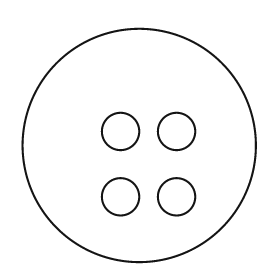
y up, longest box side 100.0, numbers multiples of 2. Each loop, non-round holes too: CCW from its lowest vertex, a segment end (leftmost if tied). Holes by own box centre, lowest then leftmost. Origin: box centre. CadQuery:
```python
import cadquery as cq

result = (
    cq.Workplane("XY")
    .moveTo(0.0, 0.0)
    .circle(50.0)
    .moveTo(-8.0, -22.0)
    .circle(8.0)
    .moveTo(16.0, -22.0)
    .circle(8.0)
    .moveTo(-8.0, 6.0)
    .circle(8.0)
    .moveTo(16.0, 6.0)
    .circle(8.0)
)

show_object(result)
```